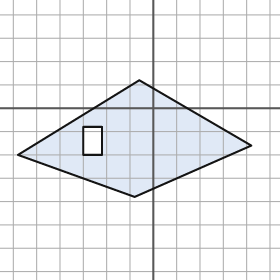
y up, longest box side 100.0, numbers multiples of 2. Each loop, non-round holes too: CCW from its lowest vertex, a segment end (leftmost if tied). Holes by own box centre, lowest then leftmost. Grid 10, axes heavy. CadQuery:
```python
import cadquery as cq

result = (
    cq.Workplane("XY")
    .moveTo(-8.0, -38.0)
    .lineTo(42.0, -16.0)
    .lineTo(-6.0, 12.0)
    .lineTo(-58.0, -20.0)
    .close()
    .moveTo(-30.0, -20.0)
    .lineTo(-22.0, -20.0)
    .lineTo(-22.0, -8.0)
    .lineTo(-30.0, -8.0)
    .close()
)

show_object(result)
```